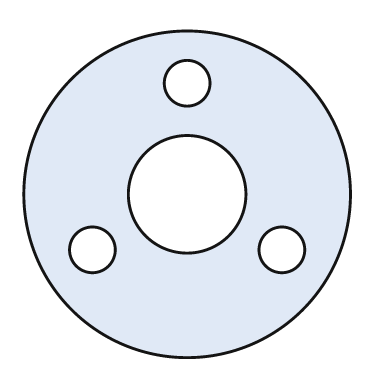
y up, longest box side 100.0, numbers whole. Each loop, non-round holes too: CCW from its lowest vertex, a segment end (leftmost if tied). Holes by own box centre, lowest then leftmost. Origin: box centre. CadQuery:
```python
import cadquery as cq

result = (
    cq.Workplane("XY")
    .moveTo(0.0, 0.0)
    .circle(50.0)
    .moveTo(-29.0, -17.0)
    .circle(7.0)
    .moveTo(29.0, -17.0)
    .circle(7.0)
    .moveTo(0.0, 0.0)
    .circle(18.0)
    .moveTo(0.0, 34.0)
    .circle(7.0)
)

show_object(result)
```